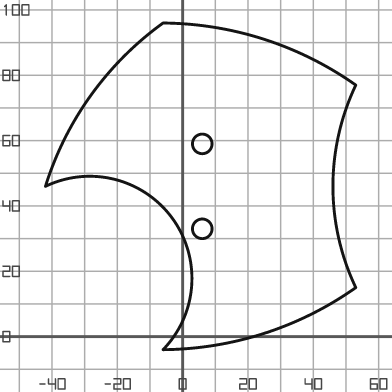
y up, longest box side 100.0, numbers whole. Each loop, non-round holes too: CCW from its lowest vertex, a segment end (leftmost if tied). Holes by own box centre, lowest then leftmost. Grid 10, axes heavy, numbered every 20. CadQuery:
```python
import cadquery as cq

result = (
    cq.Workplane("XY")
    .moveTo(-6.0, -4.0)
    .threePointArc((25.0, 1.0), (53.0, 15.0))
    .threePointArc((46.0, 46.0), (53.0, 77.0))
    .threePointArc((25.0, 91.0), (-6.0, 96.0))
    .threePointArc((-28.0, 74.0), (-42.0, 46.0))
    .threePointArc((-3.0, 36.0), (-6.0, -4.0))
    .close()
    .moveTo(6.0, 33.0)
    .circle(3.0)
    .moveTo(6.0, 59.0)
    .circle(3.0)
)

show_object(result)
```